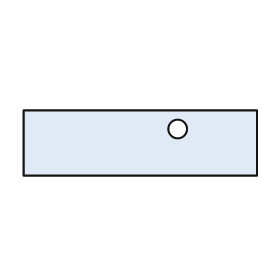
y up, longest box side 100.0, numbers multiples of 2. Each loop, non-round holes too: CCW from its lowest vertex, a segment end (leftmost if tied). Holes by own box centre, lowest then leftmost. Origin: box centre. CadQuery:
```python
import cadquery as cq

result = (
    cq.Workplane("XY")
    .moveTo(-50.0, -14.0)
    .lineTo(50.0, -14.0)
    .lineTo(50.0, 14.0)
    .lineTo(-50.0, 14.0)
    .close()
    .moveTo(16.0, 6.0)
    .circle(4.0)
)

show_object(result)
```